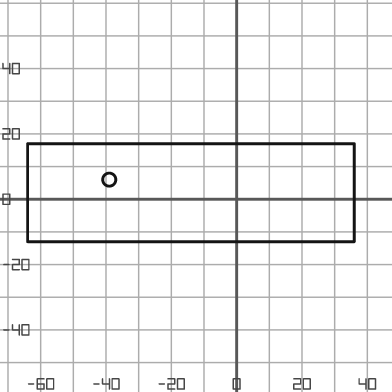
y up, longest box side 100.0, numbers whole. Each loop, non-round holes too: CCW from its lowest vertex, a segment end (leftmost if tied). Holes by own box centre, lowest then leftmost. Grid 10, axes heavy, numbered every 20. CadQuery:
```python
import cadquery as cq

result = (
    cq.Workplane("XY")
    .moveTo(-64.0, -13.0)
    .lineTo(36.0, -13.0)
    .lineTo(36.0, 17.0)
    .lineTo(-64.0, 17.0)
    .close()
    .moveTo(-39.0, 6.0)
    .circle(2.0)
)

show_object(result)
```